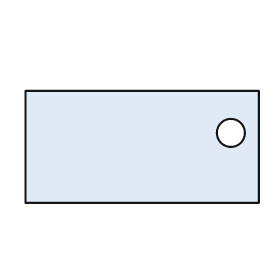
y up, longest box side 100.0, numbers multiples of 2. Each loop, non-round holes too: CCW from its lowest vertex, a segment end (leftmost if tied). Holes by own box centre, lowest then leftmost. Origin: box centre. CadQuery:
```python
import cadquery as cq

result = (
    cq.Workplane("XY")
    .moveTo(-50.0, -24.0)
    .lineTo(50.0, -24.0)
    .lineTo(50.0, 24.0)
    .lineTo(-50.0, 24.0)
    .close()
    .moveTo(38.0, 6.0)
    .circle(6.0)
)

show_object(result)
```